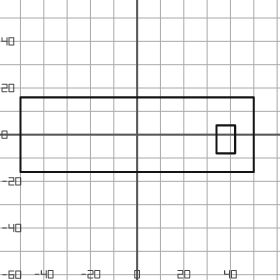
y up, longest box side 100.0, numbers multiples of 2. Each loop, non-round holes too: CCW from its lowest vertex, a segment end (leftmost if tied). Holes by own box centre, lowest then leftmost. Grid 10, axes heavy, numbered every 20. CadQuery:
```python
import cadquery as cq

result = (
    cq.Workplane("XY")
    .moveTo(-50.0, -16.0)
    .lineTo(50.0, -16.0)
    .lineTo(50.0, 16.0)
    .lineTo(-50.0, 16.0)
    .close()
    .moveTo(34.0, -8.0)
    .lineTo(42.0, -8.0)
    .lineTo(42.0, 4.0)
    .lineTo(34.0, 4.0)
    .close()
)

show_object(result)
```